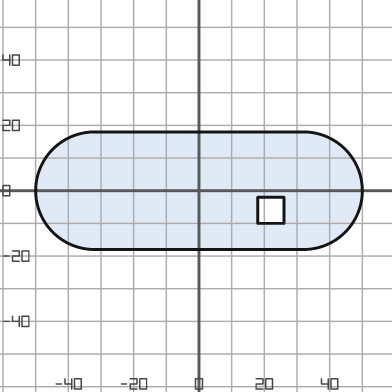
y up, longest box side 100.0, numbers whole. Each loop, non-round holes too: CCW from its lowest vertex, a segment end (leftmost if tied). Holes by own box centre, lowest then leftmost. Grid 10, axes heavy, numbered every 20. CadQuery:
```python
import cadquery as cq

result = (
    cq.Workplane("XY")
    .moveTo(-32.0, -18.0)
    .lineTo(32.0, -18.0)
    .threePointArc((50.0, 0.0), (32.0, 18.0))
    .lineTo(-32.0, 18.0)
    .threePointArc((-50.0, 0.0), (-32.0, -18.0))
    .close()
    .moveTo(18.0, -10.0)
    .lineTo(26.0, -10.0)
    .lineTo(26.0, -2.0)
    .lineTo(18.0, -2.0)
    .close()
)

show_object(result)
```